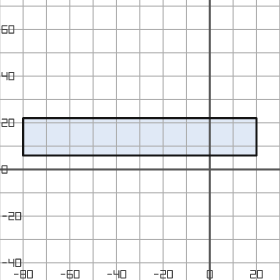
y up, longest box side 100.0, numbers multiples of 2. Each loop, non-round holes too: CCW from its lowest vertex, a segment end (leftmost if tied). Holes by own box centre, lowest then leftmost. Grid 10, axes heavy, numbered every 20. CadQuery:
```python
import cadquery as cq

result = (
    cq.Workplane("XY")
    .moveTo(-80.0, 6.0)
    .lineTo(20.0, 6.0)
    .lineTo(20.0, 22.0)
    .lineTo(-80.0, 22.0)
    .close()
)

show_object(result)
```